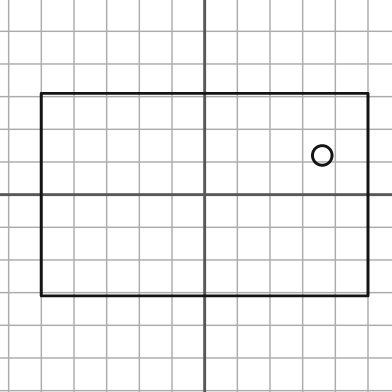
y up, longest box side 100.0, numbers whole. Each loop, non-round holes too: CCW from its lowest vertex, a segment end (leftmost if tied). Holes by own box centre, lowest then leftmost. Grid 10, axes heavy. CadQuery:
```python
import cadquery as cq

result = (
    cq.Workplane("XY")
    .moveTo(-50.0, -31.0)
    .lineTo(50.0, -31.0)
    .lineTo(50.0, 31.0)
    .lineTo(-50.0, 31.0)
    .close()
    .moveTo(36.0, 12.0)
    .circle(3.0)
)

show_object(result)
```